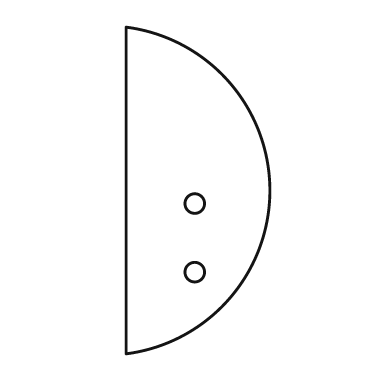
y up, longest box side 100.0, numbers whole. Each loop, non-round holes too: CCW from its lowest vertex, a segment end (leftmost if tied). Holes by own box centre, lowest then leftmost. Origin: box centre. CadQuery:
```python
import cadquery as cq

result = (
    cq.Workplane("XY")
    .moveTo(-22.0, -50.0)
    .threePointArc((22.0, 0.0), (-22.0, 50.0))
    .close()
    .moveTo(-1.0, -25.0)
    .circle(3.0)
    .moveTo(-1.0, -4.0)
    .circle(3.0)
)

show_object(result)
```